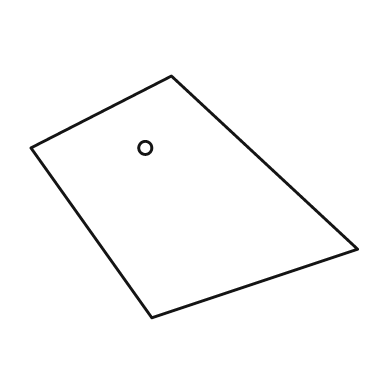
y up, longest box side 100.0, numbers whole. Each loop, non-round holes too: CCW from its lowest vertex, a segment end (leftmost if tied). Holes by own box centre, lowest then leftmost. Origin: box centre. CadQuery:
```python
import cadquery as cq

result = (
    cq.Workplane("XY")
    .moveTo(-13.0, -37.0)
    .lineTo(50.0, -16.0)
    .lineTo(-7.0, 37.0)
    .lineTo(-50.0, 15.0)
    .close()
    .moveTo(-15.0, 15.0)
    .circle(2.0)
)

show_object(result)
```